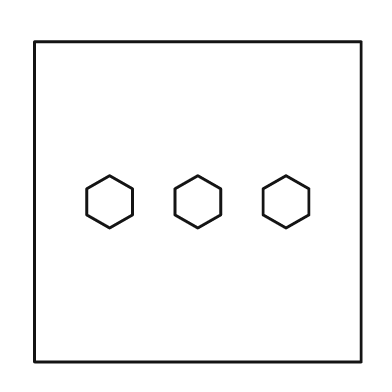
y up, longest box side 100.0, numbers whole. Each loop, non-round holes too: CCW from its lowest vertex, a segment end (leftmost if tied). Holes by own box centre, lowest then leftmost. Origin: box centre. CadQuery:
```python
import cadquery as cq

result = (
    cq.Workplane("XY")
    .moveTo(-50.0, -49.0)
    .lineTo(50.0, -49.0)
    .lineTo(50.0, 49.0)
    .lineTo(-50.0, 49.0)
    .close()
    .moveTo(-27.0, -8.0)
    .lineTo(-20.0, -4.0)
    .lineTo(-20.0, 4.0)
    .lineTo(-27.0, 8.0)
    .lineTo(-34.0, 4.0)
    .lineTo(-34.0, -4.0)
    .close()
    .moveTo(0.0, -8.0)
    .lineTo(7.0, -4.0)
    .lineTo(7.0, 4.0)
    .lineTo(0.0, 8.0)
    .lineTo(-7.0, 4.0)
    .lineTo(-7.0, -4.0)
    .close()
    .moveTo(27.0, -8.0)
    .lineTo(34.0, -4.0)
    .lineTo(34.0, 4.0)
    .lineTo(27.0, 8.0)
    .lineTo(20.0, 4.0)
    .lineTo(20.0, -4.0)
    .close()
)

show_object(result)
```